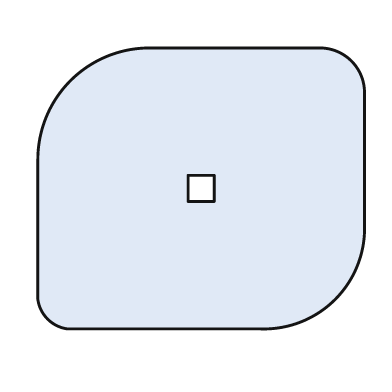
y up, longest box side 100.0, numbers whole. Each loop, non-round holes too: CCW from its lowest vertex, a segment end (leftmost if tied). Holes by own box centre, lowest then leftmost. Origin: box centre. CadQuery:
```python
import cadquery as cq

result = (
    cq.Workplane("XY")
    .moveTo(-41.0, -43.0)
    .lineTo(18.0, -43.0)
    .threePointArc((41.0, -34.0), (50.0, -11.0))
    .lineTo(50.0, 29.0)
    .threePointArc((46.0, 39.0), (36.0, 43.0))
    .lineTo(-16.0, 43.0)
    .threePointArc((-40.0, 33.0), (-50.0, 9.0))
    .lineTo(-50.0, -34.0)
    .threePointArc((-47.0, -40.0), (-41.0, -43.0))
    .close()
    .moveTo(-4.0, -4.0)
    .lineTo(4.0, -4.0)
    .lineTo(4.0, 4.0)
    .lineTo(-4.0, 4.0)
    .close()
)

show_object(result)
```